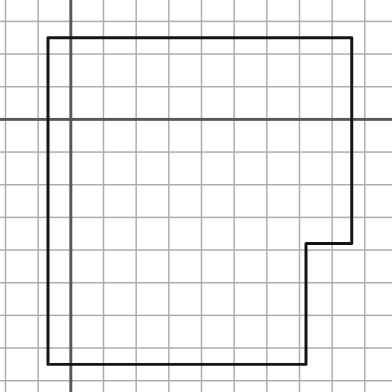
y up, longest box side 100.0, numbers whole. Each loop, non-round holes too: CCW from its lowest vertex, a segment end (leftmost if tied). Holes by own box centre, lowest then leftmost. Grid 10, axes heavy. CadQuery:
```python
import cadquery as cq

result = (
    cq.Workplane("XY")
    .moveTo(-7.0, -75.0)
    .lineTo(72.0, -75.0)
    .lineTo(72.0, -38.0)
    .lineTo(86.0, -38.0)
    .lineTo(86.0, 25.0)
    .lineTo(-7.0, 25.0)
    .close()
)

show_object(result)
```